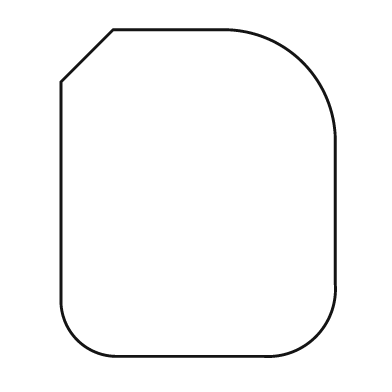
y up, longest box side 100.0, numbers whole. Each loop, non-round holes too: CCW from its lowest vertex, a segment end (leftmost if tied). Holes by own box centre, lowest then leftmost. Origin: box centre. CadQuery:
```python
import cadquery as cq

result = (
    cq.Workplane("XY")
    .moveTo(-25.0, -50.0)
    .lineTo(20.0, -50.0)
    .threePointArc((36.0, -44.0), (42.0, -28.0))
    .lineTo(42.0, 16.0)
    .threePointArc((32.0, 40.0), (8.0, 50.0))
    .lineTo(-26.0, 50.0)
    .lineTo(-42.0, 34.0)
    .lineTo(-42.0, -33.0)
    .threePointArc((-37.0, -45.0), (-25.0, -50.0))
    .close()
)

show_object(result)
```